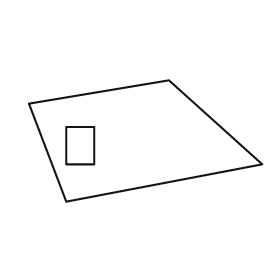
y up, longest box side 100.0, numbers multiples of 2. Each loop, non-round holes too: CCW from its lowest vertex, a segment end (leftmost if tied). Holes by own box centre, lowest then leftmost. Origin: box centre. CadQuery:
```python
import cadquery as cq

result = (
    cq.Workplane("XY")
    .moveTo(-34.0, -26.0)
    .lineTo(50.0, -10.0)
    .lineTo(10.0, 26.0)
    .lineTo(-50.0, 16.0)
    .close()
    .moveTo(-34.0, -10.0)
    .lineTo(-22.0, -10.0)
    .lineTo(-22.0, 6.0)
    .lineTo(-34.0, 6.0)
    .close()
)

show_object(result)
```